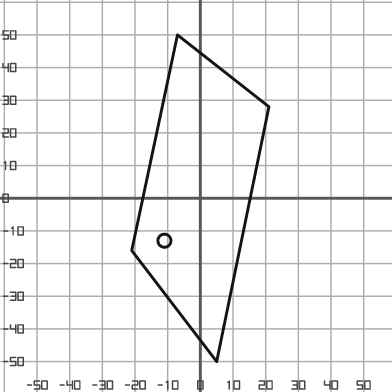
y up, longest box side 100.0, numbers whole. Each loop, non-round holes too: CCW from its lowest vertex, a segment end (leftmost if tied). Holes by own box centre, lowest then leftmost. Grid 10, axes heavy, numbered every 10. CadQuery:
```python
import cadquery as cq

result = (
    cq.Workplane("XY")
    .moveTo(5.0, -50.0)
    .lineTo(21.0, 28.0)
    .lineTo(-7.0, 50.0)
    .lineTo(-21.0, -16.0)
    .close()
    .moveTo(-11.0, -13.0)
    .circle(2.0)
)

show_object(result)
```